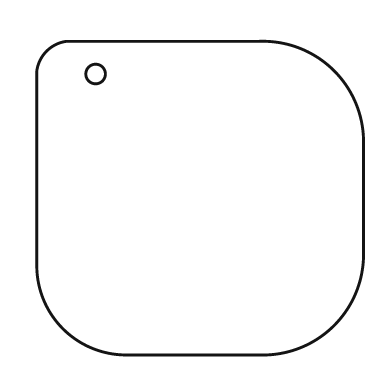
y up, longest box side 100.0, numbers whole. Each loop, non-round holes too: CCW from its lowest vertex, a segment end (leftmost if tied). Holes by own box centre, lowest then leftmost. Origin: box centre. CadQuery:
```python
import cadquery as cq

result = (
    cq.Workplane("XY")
    .moveTo(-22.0, -48.0)
    .lineTo(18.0, -48.0)
    .threePointArc((41.0, -39.0), (50.0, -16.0))
    .lineTo(50.0, 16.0)
    .threePointArc((41.0, 39.0), (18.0, 48.0))
    .lineTo(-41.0, 48.0)
    .threePointArc((-47.0, 45.0), (-50.0, 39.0))
    .lineTo(-50.0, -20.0)
    .threePointArc((-42.0, -40.0), (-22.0, -48.0))
    .close()
    .moveTo(-32.0, 38.0)
    .circle(3.0)
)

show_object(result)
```